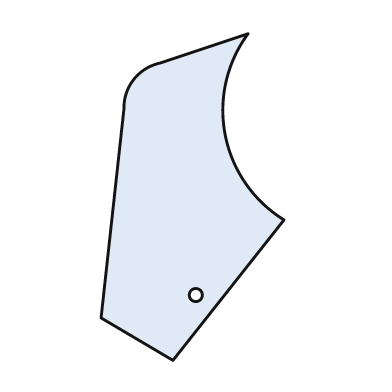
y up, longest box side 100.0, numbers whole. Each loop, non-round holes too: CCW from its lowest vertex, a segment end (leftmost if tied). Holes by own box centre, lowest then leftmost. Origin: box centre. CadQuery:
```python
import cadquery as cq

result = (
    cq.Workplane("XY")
    .moveTo(-6.0, -50.0)
    .lineTo(28.0, -7.0)
    .threePointArc((10.0, 19.0), (17.0, 50.0))
    .lineTo(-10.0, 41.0)
    .threePointArc((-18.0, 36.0), (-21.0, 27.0))
    .lineTo(-28.0, -37.0)
    .close()
    .moveTo(1.0, -30.0)
    .circle(2.0)
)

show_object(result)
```